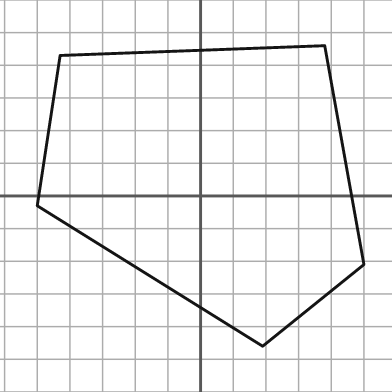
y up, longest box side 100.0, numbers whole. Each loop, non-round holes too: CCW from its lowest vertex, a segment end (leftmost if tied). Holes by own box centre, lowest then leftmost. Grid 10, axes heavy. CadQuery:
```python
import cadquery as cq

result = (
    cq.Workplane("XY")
    .moveTo(19.0, -46.0)
    .lineTo(50.0, -21.0)
    .lineTo(38.0, 46.0)
    .lineTo(-43.0, 43.0)
    .lineTo(-50.0, -3.0)
    .close()
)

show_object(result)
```